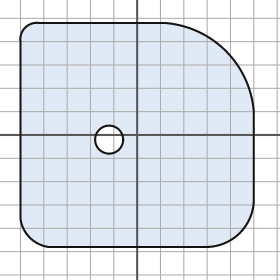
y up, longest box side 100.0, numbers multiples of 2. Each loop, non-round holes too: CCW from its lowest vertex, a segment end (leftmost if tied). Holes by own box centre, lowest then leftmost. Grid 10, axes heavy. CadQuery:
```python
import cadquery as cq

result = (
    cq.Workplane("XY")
    .moveTo(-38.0, -48.0)
    .lineTo(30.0, -48.0)
    .threePointArc((44.0, -42.0), (50.0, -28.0))
    .lineTo(50.0, 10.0)
    .threePointArc((38.0, 36.0), (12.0, 48.0))
    .lineTo(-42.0, 48.0)
    .threePointArc((-48.0, 46.0), (-50.0, 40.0))
    .lineTo(-50.0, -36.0)
    .threePointArc((-46.0, -44.0), (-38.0, -48.0))
    .close()
    .moveTo(-12.0, -2.0)
    .circle(6.0)
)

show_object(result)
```